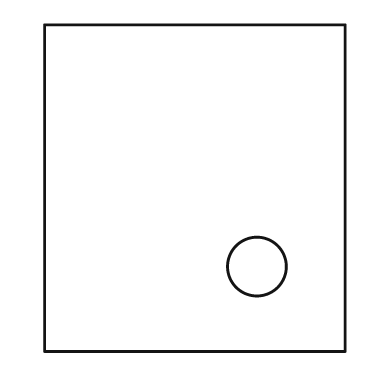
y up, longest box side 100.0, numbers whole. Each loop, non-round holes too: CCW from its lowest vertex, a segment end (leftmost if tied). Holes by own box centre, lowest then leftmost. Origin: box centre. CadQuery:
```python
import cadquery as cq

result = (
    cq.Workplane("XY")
    .moveTo(-46.0, -50.0)
    .lineTo(46.0, -50.0)
    .lineTo(46.0, 50.0)
    .lineTo(-46.0, 50.0)
    .close()
    .moveTo(19.0, -24.0)
    .circle(9.0)
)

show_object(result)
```